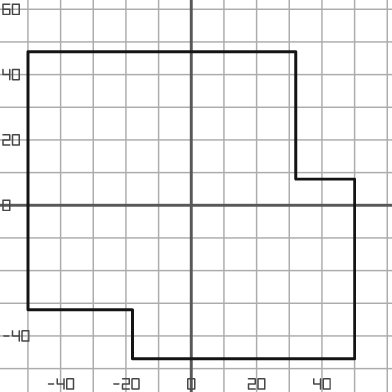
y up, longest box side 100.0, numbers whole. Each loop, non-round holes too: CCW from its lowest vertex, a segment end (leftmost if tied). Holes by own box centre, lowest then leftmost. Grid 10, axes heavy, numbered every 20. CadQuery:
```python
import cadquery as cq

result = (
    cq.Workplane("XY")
    .moveTo(-18.0, -47.0)
    .lineTo(50.0, -47.0)
    .lineTo(50.0, 8.0)
    .lineTo(32.0, 8.0)
    .lineTo(32.0, 47.0)
    .lineTo(-50.0, 47.0)
    .lineTo(-50.0, -32.0)
    .lineTo(-18.0, -32.0)
    .close()
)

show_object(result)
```